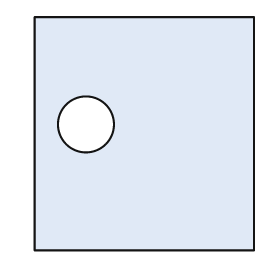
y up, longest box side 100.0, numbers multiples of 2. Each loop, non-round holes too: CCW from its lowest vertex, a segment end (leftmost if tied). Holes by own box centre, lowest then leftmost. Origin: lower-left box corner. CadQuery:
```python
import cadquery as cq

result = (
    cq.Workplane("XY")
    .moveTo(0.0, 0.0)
    .lineTo(94.0, 0.0)
    .lineTo(94.0, 100.0)
    .lineTo(0.0, 100.0)
    .close()
    .moveTo(22.0, 54.0)
    .circle(12.0)
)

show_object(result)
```